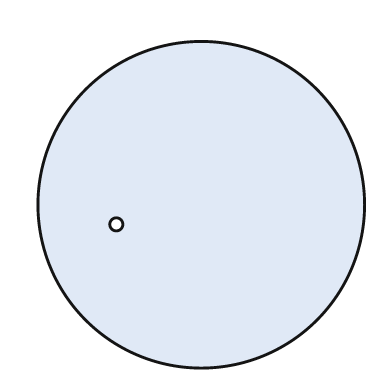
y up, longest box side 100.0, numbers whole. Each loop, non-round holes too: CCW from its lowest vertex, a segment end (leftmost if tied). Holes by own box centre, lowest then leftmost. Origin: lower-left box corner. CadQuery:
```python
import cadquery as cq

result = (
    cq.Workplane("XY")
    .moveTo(50.0, 50.0)
    .circle(50.0)
    .moveTo(24.0, 44.0)
    .circle(2.0)
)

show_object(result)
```